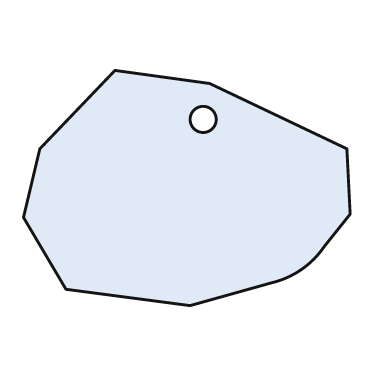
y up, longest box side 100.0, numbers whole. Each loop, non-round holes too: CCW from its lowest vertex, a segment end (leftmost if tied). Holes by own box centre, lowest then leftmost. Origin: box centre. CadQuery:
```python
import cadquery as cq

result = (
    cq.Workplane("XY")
    .moveTo(1.0, -36.0)
    .lineTo(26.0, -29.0)
    .threePointArc((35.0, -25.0), (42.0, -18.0))
    .lineTo(50.0, -8.0)
    .lineTo(49.0, 12.0)
    .lineTo(7.0, 32.0)
    .lineTo(-22.0, 36.0)
    .lineTo(-45.0, 12.0)
    .lineTo(-50.0, -9.0)
    .lineTo(-37.0, -31.0)
    .close()
    .moveTo(5.0, 21.0)
    .circle(4.0)
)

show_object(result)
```